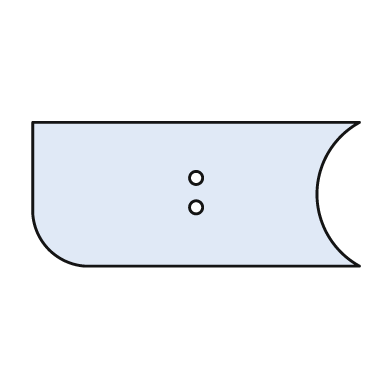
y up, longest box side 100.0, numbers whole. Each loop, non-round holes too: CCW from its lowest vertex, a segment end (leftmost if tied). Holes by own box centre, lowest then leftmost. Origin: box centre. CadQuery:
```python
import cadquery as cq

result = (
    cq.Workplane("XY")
    .moveTo(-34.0, -22.0)
    .lineTo(50.0, -22.0)
    .threePointArc((37.0, 0.0), (50.0, 22.0))
    .lineTo(-50.0, 22.0)
    .lineTo(-50.0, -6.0)
    .threePointArc((-45.0, -17.0), (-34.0, -22.0))
    .close()
    .moveTo(0.0, -4.0)
    .circle(2.0)
    .moveTo(0.0, 5.0)
    .circle(2.0)
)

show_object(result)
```